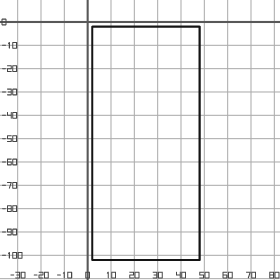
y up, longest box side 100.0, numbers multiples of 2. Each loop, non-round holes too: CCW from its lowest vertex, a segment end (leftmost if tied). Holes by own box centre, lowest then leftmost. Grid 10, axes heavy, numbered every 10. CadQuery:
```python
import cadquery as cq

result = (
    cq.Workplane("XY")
    .moveTo(2.0, -102.0)
    .lineTo(48.0, -102.0)
    .lineTo(48.0, -2.0)
    .lineTo(2.0, -2.0)
    .close()
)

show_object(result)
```